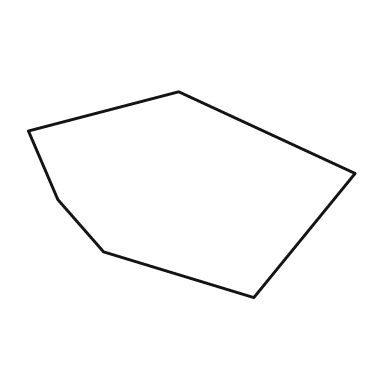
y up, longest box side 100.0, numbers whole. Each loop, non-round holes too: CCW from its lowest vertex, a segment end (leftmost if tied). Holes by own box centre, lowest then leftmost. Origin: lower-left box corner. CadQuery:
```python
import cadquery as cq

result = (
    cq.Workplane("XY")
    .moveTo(69.0, 0.0)
    .lineTo(100.0, 38.0)
    .lineTo(46.0, 63.0)
    .lineTo(0.0, 51.0)
    .lineTo(9.0, 30.0)
    .lineTo(23.0, 14.0)
    .close()
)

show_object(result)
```